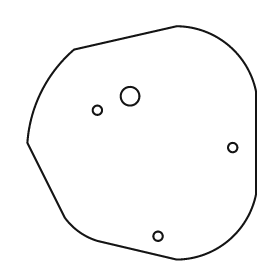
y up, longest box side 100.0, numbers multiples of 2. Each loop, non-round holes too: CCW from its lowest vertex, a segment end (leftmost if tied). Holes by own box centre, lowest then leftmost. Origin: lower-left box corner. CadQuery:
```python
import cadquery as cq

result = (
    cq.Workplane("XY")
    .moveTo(64.0, 0.0)
    .threePointArc((86.0, 8.0), (98.0, 28.0))
    .lineTo(98.0, 72.0)
    .threePointArc((86.0, 92.0), (64.0, 100.0))
    .lineTo(20.0, 90.0)
    .threePointArc((6.0, 72.0), (0.0, 50.0))
    .lineTo(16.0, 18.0)
    .threePointArc((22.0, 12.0), (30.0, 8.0))
    .close()
    .moveTo(56.0, 10.0)
    .circle(2.0)
    .moveTo(88.0, 48.0)
    .circle(2.0)
    .moveTo(30.0, 64.0)
    .circle(2.0)
    .moveTo(44.0, 70.0)
    .circle(4.0)
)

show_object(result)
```